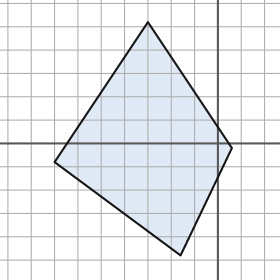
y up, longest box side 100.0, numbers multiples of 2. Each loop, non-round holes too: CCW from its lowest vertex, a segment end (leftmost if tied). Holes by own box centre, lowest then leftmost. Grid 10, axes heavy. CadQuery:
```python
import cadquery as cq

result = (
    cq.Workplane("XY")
    .moveTo(-16.0, -48.0)
    .lineTo(6.0, -2.0)
    .lineTo(-30.0, 52.0)
    .lineTo(-70.0, -8.0)
    .close()
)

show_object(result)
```